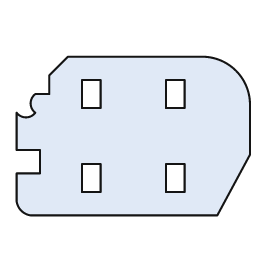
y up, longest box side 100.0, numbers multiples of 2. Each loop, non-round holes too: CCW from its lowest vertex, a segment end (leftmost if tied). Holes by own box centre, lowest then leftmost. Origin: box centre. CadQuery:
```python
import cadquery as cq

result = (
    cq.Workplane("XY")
    .moveTo(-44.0, -34.0)
    .lineTo(36.0, -34.0)
    .lineTo(50.0, -8.0)
    .lineTo(50.0, 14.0)
    .threePointArc((44.0, 28.0), (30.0, 34.0))
    .lineTo(-28.0, 34.0)
    .lineTo(-36.0, 26.0)
    .lineTo(-36.0, 18.0)
    .lineTo(-42.0, 18.0)
    .threePointArc((-44.0, 14.0), (-42.0, 10.0))
    .threePointArc((-46.0, 8.0), (-50.0, 10.0))
    .lineTo(-50.0, -6.0)
    .lineTo(-40.0, -6.0)
    .lineTo(-40.0, -16.0)
    .lineTo(-50.0, -16.0)
    .lineTo(-50.0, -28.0)
    .threePointArc((-48.0, -32.0), (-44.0, -34.0))
    .close()
    .moveTo(-22.0, -24.0)
    .lineTo(-14.0, -24.0)
    .lineTo(-14.0, -12.0)
    .lineTo(-22.0, -12.0)
    .close()
    .moveTo(14.0, -24.0)
    .lineTo(22.0, -24.0)
    .lineTo(22.0, -12.0)
    .lineTo(14.0, -12.0)
    .close()
    .moveTo(-22.0, 12.0)
    .lineTo(-14.0, 12.0)
    .lineTo(-14.0, 24.0)
    .lineTo(-22.0, 24.0)
    .close()
    .moveTo(14.0, 12.0)
    .lineTo(22.0, 12.0)
    .lineTo(22.0, 24.0)
    .lineTo(14.0, 24.0)
    .close()
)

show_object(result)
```